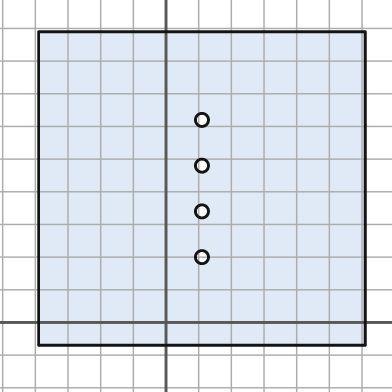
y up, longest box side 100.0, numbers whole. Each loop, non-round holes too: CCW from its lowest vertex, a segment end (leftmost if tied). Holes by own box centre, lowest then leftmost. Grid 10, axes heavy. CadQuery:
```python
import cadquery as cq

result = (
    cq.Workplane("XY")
    .moveTo(-39.0, -7.0)
    .lineTo(61.0, -7.0)
    .lineTo(61.0, 89.0)
    .lineTo(-39.0, 89.0)
    .close()
    .moveTo(11.0, 20.0)
    .circle(2.0)
    .moveTo(11.0, 34.0)
    .circle(2.0)
    .moveTo(11.0, 48.0)
    .circle(2.0)
    .moveTo(11.0, 62.0)
    .circle(2.0)
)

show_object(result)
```